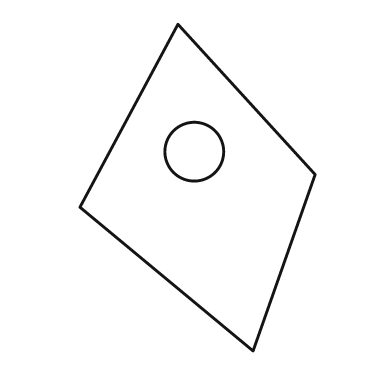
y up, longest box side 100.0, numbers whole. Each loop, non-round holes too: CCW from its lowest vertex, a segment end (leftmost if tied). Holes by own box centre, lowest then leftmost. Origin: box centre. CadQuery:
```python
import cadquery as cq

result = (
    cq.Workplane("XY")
    .moveTo(17.0, -50.0)
    .lineTo(36.0, 4.0)
    .lineTo(-6.0, 50.0)
    .lineTo(-36.0, -6.0)
    .close()
    .moveTo(-1.0, 11.0)
    .circle(9.0)
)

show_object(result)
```